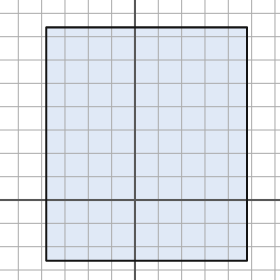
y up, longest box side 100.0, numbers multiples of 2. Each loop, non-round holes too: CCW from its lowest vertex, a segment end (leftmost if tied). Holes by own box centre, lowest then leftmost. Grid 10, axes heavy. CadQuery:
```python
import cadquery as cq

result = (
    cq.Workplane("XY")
    .moveTo(-38.0, -26.0)
    .lineTo(48.0, -26.0)
    .lineTo(48.0, 74.0)
    .lineTo(-38.0, 74.0)
    .close()
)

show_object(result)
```